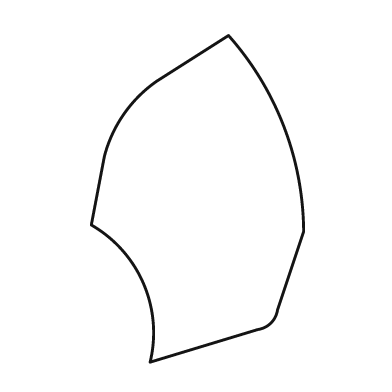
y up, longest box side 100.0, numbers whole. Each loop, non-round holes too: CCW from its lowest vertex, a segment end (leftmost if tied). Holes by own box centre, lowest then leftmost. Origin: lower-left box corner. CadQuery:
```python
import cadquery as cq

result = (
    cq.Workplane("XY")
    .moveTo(18.0, 0.0)
    .lineTo(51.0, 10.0)
    .threePointArc((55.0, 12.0), (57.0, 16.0))
    .lineTo(65.0, 40.0)
    .threePointArc((59.0, 72.0), (42.0, 100.0))
    .lineTo(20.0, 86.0)
    .threePointArc((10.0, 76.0), (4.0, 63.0))
    .lineTo(0.0, 42.0)
    .threePointArc((16.0, 24.0), (18.0, 0.0))
    .close()
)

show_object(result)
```